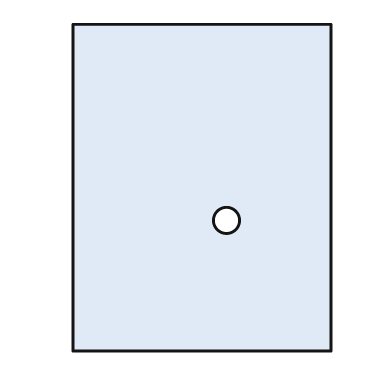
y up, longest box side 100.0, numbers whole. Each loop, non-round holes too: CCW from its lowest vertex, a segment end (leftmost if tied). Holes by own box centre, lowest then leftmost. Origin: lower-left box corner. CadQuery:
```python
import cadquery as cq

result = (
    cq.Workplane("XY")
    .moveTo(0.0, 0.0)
    .lineTo(79.0, 0.0)
    .lineTo(79.0, 100.0)
    .lineTo(0.0, 100.0)
    .close()
    .moveTo(47.0, 40.0)
    .circle(4.0)
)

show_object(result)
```